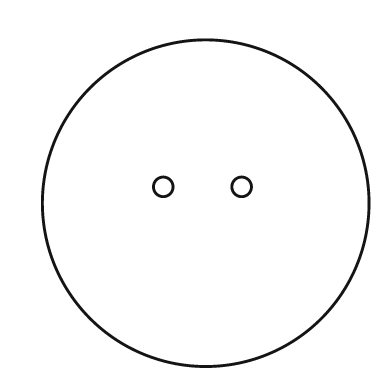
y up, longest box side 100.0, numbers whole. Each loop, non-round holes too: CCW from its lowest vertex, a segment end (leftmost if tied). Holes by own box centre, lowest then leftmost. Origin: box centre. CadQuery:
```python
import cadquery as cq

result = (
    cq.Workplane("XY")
    .moveTo(0.0, 0.0)
    .circle(50.0)
    .moveTo(-13.0, 5.0)
    .circle(3.0)
    .moveTo(11.0, 5.0)
    .circle(3.0)
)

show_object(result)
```